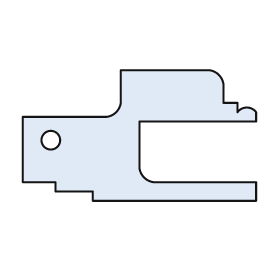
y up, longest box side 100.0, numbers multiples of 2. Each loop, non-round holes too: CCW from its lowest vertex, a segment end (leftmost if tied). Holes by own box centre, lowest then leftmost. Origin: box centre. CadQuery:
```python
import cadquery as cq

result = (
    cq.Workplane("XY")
    .moveTo(-20.0, -28.0)
    .lineTo(50.0, -28.0)
    .lineTo(50.0, -20.0)
    .lineTo(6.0, -20.0)
    .threePointArc((2.0, -18.0), (0.0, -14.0))
    .lineTo(0.0, 6.0)
    .lineTo(50.0, 6.0)
    .lineTo(50.0, 10.0)
    .threePointArc((46.0, 12.0), (42.0, 10.0))
    .lineTo(42.0, 14.0)
    .lineTo(36.0, 14.0)
    .lineTo(36.0, 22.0)
    .threePointArc((34.0, 26.0), (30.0, 28.0))
    .lineTo(-8.0, 28.0)
    .lineTo(-8.0, 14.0)
    .threePointArc((-10.0, 10.0), (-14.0, 8.0))
    .lineTo(-50.0, 8.0)
    .lineTo(-50.0, -20.0)
    .lineTo(-36.0, -20.0)
    .lineTo(-36.0, -24.0)
    .lineTo(-20.0, -24.0)
    .close()
    .moveTo(-38.0, -2.0)
    .circle(4.0)
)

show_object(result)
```